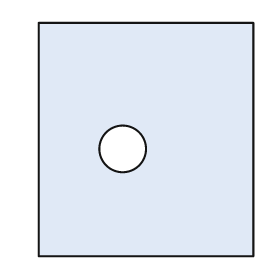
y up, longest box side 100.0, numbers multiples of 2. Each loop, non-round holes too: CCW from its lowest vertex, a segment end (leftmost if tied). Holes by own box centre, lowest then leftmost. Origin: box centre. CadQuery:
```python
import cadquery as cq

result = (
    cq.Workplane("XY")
    .moveTo(-46.0, -50.0)
    .lineTo(46.0, -50.0)
    .lineTo(46.0, 50.0)
    .lineTo(-46.0, 50.0)
    .close()
    .moveTo(-10.0, -4.0)
    .circle(10.0)
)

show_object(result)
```